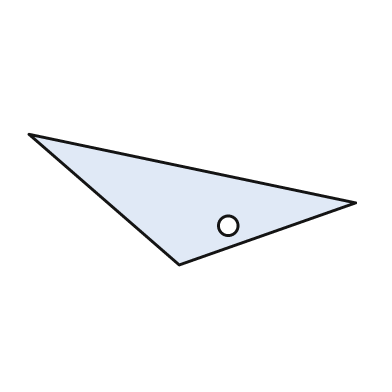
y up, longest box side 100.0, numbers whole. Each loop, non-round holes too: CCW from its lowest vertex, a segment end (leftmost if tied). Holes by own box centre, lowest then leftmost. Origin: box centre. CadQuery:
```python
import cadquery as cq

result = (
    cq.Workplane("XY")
    .moveTo(-4.0, -20.0)
    .lineTo(50.0, -1.0)
    .lineTo(-50.0, 20.0)
    .close()
    .moveTo(11.0, -8.0)
    .circle(3.0)
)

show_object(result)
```